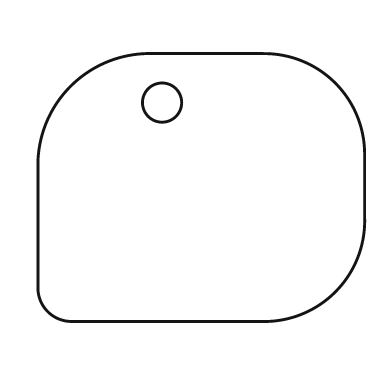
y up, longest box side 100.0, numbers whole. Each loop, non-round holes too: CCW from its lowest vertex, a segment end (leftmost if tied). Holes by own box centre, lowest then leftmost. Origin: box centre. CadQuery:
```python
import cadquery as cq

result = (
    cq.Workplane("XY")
    .moveTo(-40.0, -41.0)
    .lineTo(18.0, -41.0)
    .threePointArc((41.0, -32.0), (50.0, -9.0))
    .lineTo(50.0, 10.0)
    .threePointArc((41.0, 32.0), (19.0, 41.0))
    .lineTo(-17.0, 41.0)
    .threePointArc((-40.0, 31.0), (-50.0, 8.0))
    .lineTo(-50.0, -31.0)
    .threePointArc((-47.0, -38.0), (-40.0, -41.0))
    .close()
    .moveTo(-12.0, 26.0)
    .circle(6.0)
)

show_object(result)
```